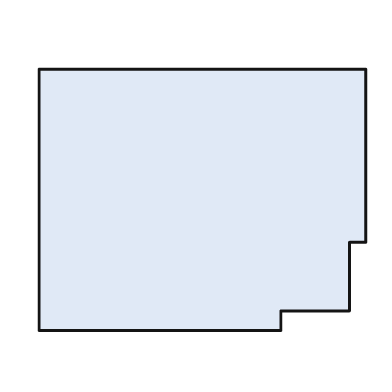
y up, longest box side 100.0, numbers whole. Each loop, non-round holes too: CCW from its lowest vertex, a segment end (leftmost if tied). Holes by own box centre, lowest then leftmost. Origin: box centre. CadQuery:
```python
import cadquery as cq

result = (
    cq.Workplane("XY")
    .moveTo(-50.0, -40.0)
    .lineTo(24.0, -40.0)
    .lineTo(24.0, -34.0)
    .lineTo(45.0, -34.0)
    .lineTo(45.0, -13.0)
    .lineTo(50.0, -13.0)
    .lineTo(50.0, 40.0)
    .lineTo(-50.0, 40.0)
    .close()
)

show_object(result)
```